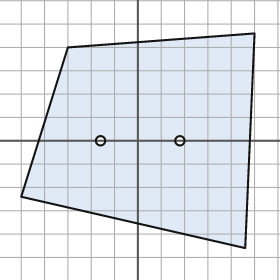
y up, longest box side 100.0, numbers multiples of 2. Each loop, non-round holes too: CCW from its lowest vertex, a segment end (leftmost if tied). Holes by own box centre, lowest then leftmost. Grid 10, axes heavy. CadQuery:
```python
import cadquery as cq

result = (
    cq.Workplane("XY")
    .moveTo(46.0, -46.0)
    .lineTo(50.0, 46.0)
    .lineTo(-30.0, 40.0)
    .lineTo(-50.0, -24.0)
    .close()
    .moveTo(-16.0, 0.0)
    .circle(2.0)
    .moveTo(18.0, 0.0)
    .circle(2.0)
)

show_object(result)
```